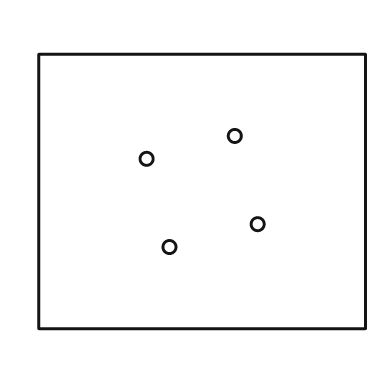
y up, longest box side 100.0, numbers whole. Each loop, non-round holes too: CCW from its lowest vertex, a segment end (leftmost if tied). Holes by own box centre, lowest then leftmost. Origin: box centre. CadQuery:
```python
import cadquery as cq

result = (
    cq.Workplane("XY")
    .moveTo(-50.0, -42.0)
    .lineTo(50.0, -42.0)
    .lineTo(50.0, 42.0)
    .lineTo(-50.0, 42.0)
    .close()
    .moveTo(-10.0, -17.0)
    .circle(2.0)
    .moveTo(17.0, -10.0)
    .circle(2.0)
    .moveTo(-17.0, 10.0)
    .circle(2.0)
    .moveTo(10.0, 17.0)
    .circle(2.0)
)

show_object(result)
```